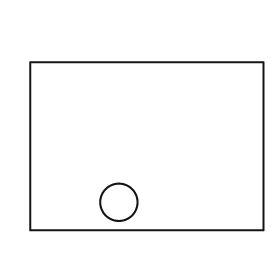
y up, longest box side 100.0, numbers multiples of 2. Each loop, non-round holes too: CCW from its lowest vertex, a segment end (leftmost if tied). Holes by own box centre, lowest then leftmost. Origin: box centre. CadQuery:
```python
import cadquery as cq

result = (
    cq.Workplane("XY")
    .moveTo(-50.0, -36.0)
    .lineTo(50.0, -36.0)
    .lineTo(50.0, 36.0)
    .lineTo(-50.0, 36.0)
    .close()
    .moveTo(-12.0, -24.0)
    .circle(8.0)
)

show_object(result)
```